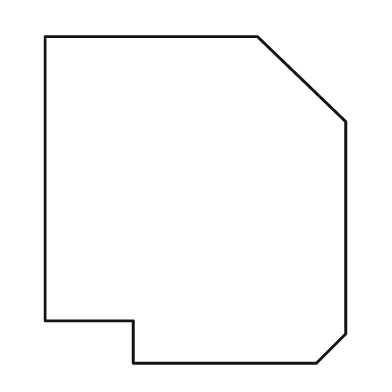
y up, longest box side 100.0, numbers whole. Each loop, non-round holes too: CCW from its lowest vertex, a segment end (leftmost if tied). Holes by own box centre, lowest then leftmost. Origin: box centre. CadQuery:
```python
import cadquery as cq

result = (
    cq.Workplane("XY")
    .moveTo(-19.0, -50.0)
    .lineTo(37.0, -50.0)
    .lineTo(46.0, -41.0)
    .lineTo(46.0, 24.0)
    .lineTo(19.0, 50.0)
    .lineTo(-46.0, 50.0)
    .lineTo(-46.0, -37.0)
    .lineTo(-19.0, -37.0)
    .close()
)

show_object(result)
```